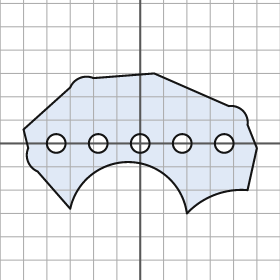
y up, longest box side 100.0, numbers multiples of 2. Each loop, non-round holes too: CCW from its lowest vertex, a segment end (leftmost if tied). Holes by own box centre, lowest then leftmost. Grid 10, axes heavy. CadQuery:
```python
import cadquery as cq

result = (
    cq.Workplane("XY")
    .moveTo(20.0, -30.0)
    .threePointArc((32.0, -22.0), (46.0, -20.0))
    .lineTo(50.0, -2.0)
    .lineTo(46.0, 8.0)
    .threePointArc((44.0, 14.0), (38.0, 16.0))
    .lineTo(6.0, 30.0)
    .lineTo(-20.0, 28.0)
    .threePointArc((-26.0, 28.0), (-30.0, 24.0))
    .lineTo(-50.0, 6.0)
    .lineTo(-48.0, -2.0)
    .threePointArc((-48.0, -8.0), (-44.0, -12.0))
    .lineTo(-30.0, -28.0)
    .threePointArc((-4.0, -8.0), (20.0, -30.0))
    .close()
    .moveTo(-36.0, 0.0)
    .circle(4.0)
    .moveTo(-18.0, 0.0)
    .circle(4.0)
    .moveTo(0.0, 0.0)
    .circle(4.0)
    .moveTo(18.0, 0.0)
    .circle(4.0)
    .moveTo(36.0, 0.0)
    .circle(4.0)
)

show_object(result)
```